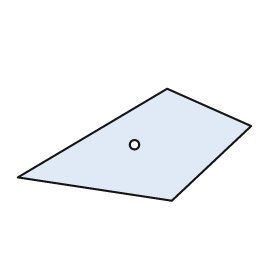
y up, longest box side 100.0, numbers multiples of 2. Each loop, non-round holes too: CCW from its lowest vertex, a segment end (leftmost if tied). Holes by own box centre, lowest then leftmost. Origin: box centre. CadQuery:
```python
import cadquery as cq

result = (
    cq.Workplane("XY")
    .moveTo(16.0, -24.0)
    .lineTo(50.0, 8.0)
    .lineTo(14.0, 24.0)
    .lineTo(-50.0, -14.0)
    .close()
    .moveTo(0.0, 0.0)
    .circle(2.0)
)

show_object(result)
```